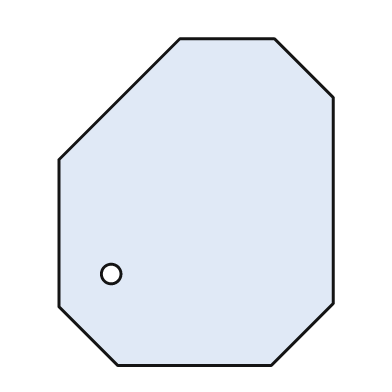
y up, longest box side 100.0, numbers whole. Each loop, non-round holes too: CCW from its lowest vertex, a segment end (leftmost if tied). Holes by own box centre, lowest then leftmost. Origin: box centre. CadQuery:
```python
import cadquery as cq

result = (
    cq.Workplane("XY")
    .moveTo(-24.0, -50.0)
    .lineTo(23.0, -50.0)
    .lineTo(42.0, -31.0)
    .lineTo(42.0, 32.0)
    .lineTo(24.0, 50.0)
    .lineTo(-5.0, 50.0)
    .lineTo(-42.0, 13.0)
    .lineTo(-42.0, -32.0)
    .close()
    .moveTo(-26.0, -22.0)
    .circle(3.0)
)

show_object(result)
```